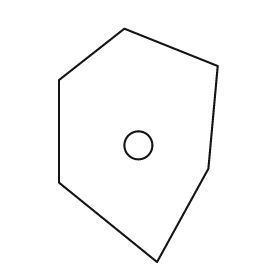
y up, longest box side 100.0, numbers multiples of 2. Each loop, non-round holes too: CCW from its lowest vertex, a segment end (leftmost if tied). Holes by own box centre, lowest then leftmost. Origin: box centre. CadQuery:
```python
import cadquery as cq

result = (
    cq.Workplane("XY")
    .moveTo(8.0, -50.0)
    .lineTo(30.0, -10.0)
    .lineTo(34.0, 34.0)
    .lineTo(-6.0, 50.0)
    .lineTo(-34.0, 28.0)
    .lineTo(-34.0, -16.0)
    .close()
    .moveTo(0.0, 0.0)
    .circle(6.0)
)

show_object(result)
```